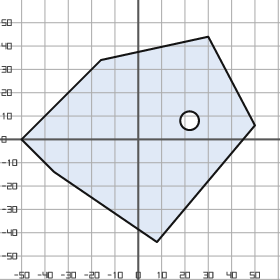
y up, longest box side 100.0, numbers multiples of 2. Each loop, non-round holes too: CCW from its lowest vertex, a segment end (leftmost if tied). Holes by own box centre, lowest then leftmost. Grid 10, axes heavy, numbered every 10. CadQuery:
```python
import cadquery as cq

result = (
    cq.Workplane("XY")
    .moveTo(8.0, -44.0)
    .lineTo(50.0, 6.0)
    .lineTo(30.0, 44.0)
    .lineTo(-16.0, 34.0)
    .lineTo(-50.0, 0.0)
    .lineTo(-36.0, -14.0)
    .close()
    .moveTo(22.0, 8.0)
    .circle(4.0)
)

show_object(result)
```